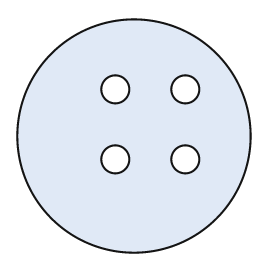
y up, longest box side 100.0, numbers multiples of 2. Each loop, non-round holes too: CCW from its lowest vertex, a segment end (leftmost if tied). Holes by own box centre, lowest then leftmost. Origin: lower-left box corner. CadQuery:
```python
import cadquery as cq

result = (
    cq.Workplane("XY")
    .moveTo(50.0, 50.0)
    .circle(50.0)
    .moveTo(42.0, 40.0)
    .circle(6.0)
    .moveTo(72.0, 40.0)
    .circle(6.0)
    .moveTo(42.0, 70.0)
    .circle(6.0)
    .moveTo(72.0, 70.0)
    .circle(6.0)
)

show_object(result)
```